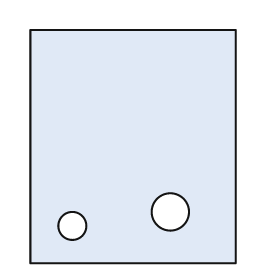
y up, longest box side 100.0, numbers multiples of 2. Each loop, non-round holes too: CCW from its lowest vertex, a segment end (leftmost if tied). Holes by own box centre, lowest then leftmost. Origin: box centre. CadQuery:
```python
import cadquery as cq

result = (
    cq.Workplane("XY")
    .moveTo(-44.0, -50.0)
    .lineTo(44.0, -50.0)
    .lineTo(44.0, 50.0)
    .lineTo(-44.0, 50.0)
    .close()
    .moveTo(-26.0, -34.0)
    .circle(6.0)
    .moveTo(16.0, -28.0)
    .circle(8.0)
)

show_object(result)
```